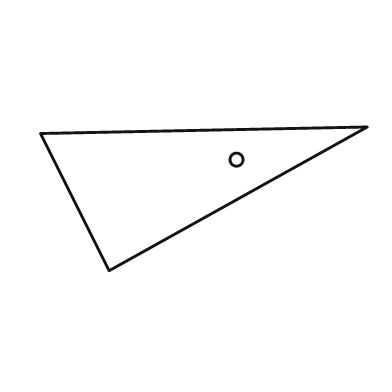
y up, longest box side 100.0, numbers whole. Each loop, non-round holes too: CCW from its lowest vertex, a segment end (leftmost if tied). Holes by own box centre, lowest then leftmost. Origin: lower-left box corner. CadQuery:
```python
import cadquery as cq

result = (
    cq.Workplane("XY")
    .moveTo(21.0, 0.0)
    .lineTo(100.0, 44.0)
    .lineTo(0.0, 42.0)
    .close()
    .moveTo(60.0, 34.0)
    .circle(2.0)
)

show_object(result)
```